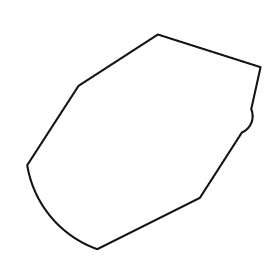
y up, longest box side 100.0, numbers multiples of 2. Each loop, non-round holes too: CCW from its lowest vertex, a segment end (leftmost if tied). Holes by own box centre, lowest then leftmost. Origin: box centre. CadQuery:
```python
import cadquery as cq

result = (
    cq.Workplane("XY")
    .moveTo(-20.0, -46.0)
    .lineTo(24.0, -24.0)
    .lineTo(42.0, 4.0)
    .threePointArc((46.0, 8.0), (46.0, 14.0))
    .lineTo(50.0, 32.0)
    .lineTo(6.0, 46.0)
    .lineTo(-28.0, 24.0)
    .lineTo(-50.0, -10.0)
    .threePointArc((-40.0, -32.0), (-20.0, -46.0))
    .close()
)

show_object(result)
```